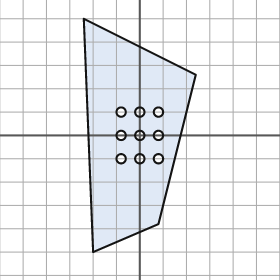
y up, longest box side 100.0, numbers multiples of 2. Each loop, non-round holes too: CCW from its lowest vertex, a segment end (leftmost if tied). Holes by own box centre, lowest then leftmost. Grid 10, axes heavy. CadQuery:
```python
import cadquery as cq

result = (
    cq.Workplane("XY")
    .moveTo(-20.0, -50.0)
    .lineTo(8.0, -38.0)
    .lineTo(24.0, 26.0)
    .lineTo(-24.0, 50.0)
    .close()
    .moveTo(-8.0, -10.0)
    .circle(2.0)
    .moveTo(0.0, -10.0)
    .circle(2.0)
    .moveTo(8.0, -10.0)
    .circle(2.0)
    .moveTo(-8.0, 0.0)
    .circle(2.0)
    .moveTo(0.0, 0.0)
    .circle(2.0)
    .moveTo(8.0, 0.0)
    .circle(2.0)
    .moveTo(-8.0, 10.0)
    .circle(2.0)
    .moveTo(0.0, 10.0)
    .circle(2.0)
    .moveTo(8.0, 10.0)
    .circle(2.0)
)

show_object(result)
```